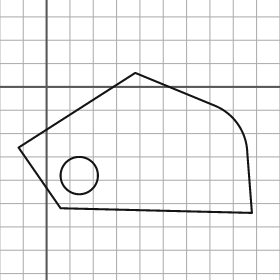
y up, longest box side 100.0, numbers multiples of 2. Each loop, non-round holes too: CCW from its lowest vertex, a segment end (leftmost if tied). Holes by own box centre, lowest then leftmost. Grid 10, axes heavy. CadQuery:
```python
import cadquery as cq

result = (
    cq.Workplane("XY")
    .moveTo(88.0, -54.0)
    .lineTo(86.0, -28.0)
    .threePointArc((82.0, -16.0), (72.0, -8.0))
    .lineTo(38.0, 6.0)
    .lineTo(-12.0, -26.0)
    .lineTo(6.0, -52.0)
    .close()
    .moveTo(14.0, -38.0)
    .circle(8.0)
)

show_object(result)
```